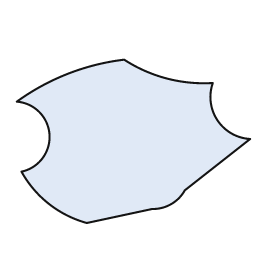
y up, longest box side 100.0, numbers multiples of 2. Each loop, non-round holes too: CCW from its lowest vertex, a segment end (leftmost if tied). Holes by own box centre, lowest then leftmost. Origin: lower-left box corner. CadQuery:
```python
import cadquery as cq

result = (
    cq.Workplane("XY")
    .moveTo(30.0, 0.0)
    .lineTo(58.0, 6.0)
    .threePointArc((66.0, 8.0), (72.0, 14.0))
    .lineTo(100.0, 36.0)
    .threePointArc((86.0, 44.0), (84.0, 60.0))
    .threePointArc((64.0, 62.0), (46.0, 70.0))
    .threePointArc((22.0, 64.0), (0.0, 52.0))
    .threePointArc((14.0, 38.0), (2.0, 22.0))
    .threePointArc((14.0, 8.0), (30.0, 0.0))
    .close()
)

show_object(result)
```